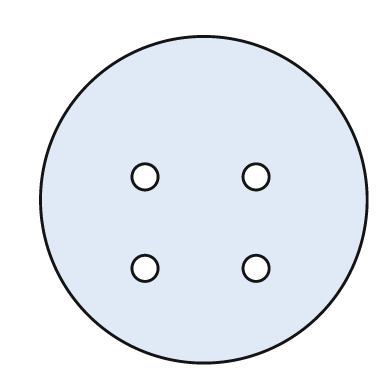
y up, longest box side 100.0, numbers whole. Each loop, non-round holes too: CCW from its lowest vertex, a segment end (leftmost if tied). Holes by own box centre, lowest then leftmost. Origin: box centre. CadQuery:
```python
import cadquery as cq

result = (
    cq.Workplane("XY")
    .moveTo(0.0, 0.0)
    .circle(50.0)
    .moveTo(-18.0, -21.0)
    .circle(4.0)
    .moveTo(16.0, -21.0)
    .circle(4.0)
    .moveTo(-18.0, 7.0)
    .circle(4.0)
    .moveTo(16.0, 7.0)
    .circle(4.0)
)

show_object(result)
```